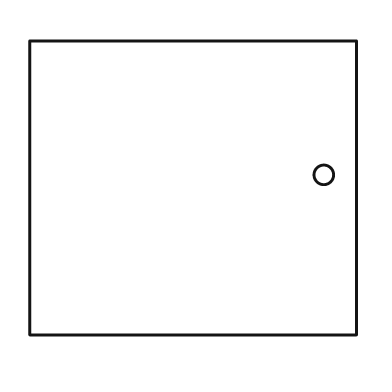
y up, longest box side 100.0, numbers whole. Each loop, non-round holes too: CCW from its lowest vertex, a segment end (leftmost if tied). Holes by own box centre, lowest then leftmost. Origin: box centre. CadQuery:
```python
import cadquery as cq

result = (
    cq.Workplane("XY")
    .moveTo(-50.0, -45.0)
    .lineTo(50.0, -45.0)
    .lineTo(50.0, 45.0)
    .lineTo(-50.0, 45.0)
    .close()
    .moveTo(40.0, 4.0)
    .circle(3.0)
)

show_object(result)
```